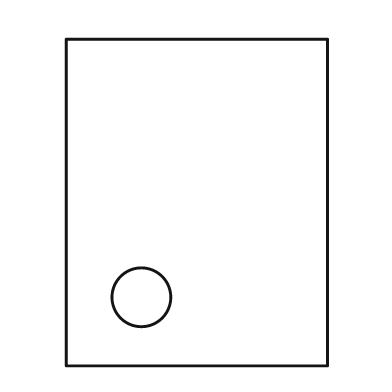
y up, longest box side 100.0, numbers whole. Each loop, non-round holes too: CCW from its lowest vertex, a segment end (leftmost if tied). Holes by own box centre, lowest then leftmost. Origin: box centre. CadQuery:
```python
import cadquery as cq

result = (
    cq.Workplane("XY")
    .moveTo(-40.0, -50.0)
    .lineTo(40.0, -50.0)
    .lineTo(40.0, 50.0)
    .lineTo(-40.0, 50.0)
    .close()
    .moveTo(-17.0, -29.0)
    .circle(9.0)
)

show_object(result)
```